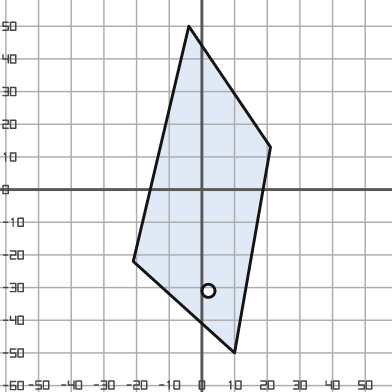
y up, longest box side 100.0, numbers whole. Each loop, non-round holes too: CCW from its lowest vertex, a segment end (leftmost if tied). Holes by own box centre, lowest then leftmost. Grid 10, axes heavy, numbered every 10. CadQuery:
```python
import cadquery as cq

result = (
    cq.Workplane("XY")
    .moveTo(10.0, -50.0)
    .lineTo(21.0, 13.0)
    .lineTo(-4.0, 50.0)
    .lineTo(-21.0, -22.0)
    .close()
    .moveTo(2.0, -31.0)
    .circle(2.0)
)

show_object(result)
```